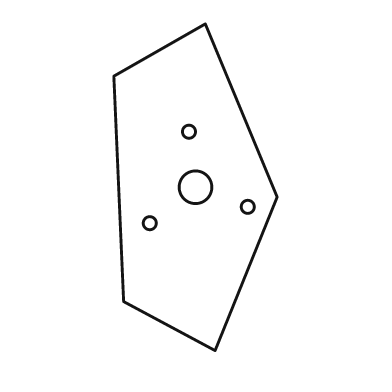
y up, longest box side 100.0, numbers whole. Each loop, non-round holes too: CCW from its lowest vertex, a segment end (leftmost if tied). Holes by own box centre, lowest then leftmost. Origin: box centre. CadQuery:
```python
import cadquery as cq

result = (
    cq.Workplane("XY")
    .moveTo(6.0, -50.0)
    .lineTo(25.0, -3.0)
    .lineTo(3.0, 50.0)
    .lineTo(-25.0, 34.0)
    .lineTo(-22.0, -35.0)
    .close()
    .moveTo(-14.0, -11.0)
    .circle(2.0)
    .moveTo(16.0, -6.0)
    .circle(2.0)
    .moveTo(0.0, 0.0)
    .circle(5.0)
    .moveTo(-2.0, 17.0)
    .circle(2.0)
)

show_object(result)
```